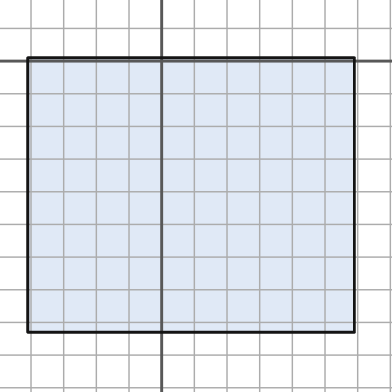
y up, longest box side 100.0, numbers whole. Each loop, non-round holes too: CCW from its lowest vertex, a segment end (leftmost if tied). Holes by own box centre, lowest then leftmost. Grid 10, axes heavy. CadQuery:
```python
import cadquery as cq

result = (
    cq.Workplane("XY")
    .moveTo(-41.0, -83.0)
    .lineTo(59.0, -83.0)
    .lineTo(59.0, 1.0)
    .lineTo(-41.0, 1.0)
    .close()
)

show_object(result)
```